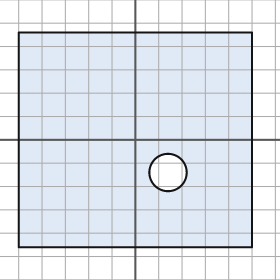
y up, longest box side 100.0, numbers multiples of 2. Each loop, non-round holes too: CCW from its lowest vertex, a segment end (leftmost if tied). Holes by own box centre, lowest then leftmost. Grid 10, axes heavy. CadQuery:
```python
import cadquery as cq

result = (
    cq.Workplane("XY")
    .moveTo(-50.0, -46.0)
    .lineTo(50.0, -46.0)
    .lineTo(50.0, 46.0)
    .lineTo(-50.0, 46.0)
    .close()
    .moveTo(14.0, -14.0)
    .circle(8.0)
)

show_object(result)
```